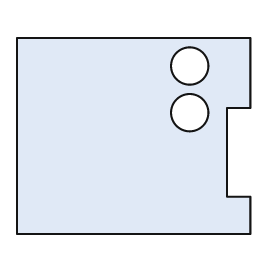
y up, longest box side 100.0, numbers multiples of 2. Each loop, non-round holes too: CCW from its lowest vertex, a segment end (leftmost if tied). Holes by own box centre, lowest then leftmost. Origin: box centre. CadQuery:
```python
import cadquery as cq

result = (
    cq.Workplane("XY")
    .moveTo(-50.0, -42.0)
    .lineTo(50.0, -42.0)
    .lineTo(50.0, -26.0)
    .lineTo(40.0, -26.0)
    .lineTo(40.0, 12.0)
    .lineTo(50.0, 12.0)
    .lineTo(50.0, 42.0)
    .lineTo(-50.0, 42.0)
    .close()
    .moveTo(24.0, 10.0)
    .circle(8.0)
    .moveTo(24.0, 30.0)
    .circle(8.0)
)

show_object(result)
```